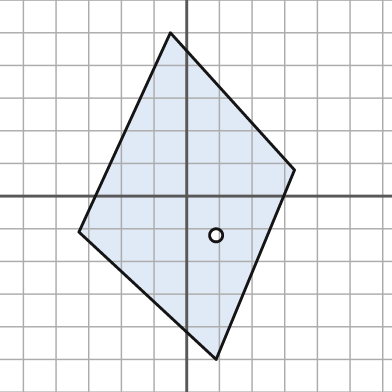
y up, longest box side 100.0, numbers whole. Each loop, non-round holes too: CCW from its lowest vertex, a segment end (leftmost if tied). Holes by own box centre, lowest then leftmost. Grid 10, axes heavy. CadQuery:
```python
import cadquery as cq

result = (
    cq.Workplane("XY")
    .moveTo(9.0, -50.0)
    .lineTo(33.0, 8.0)
    .lineTo(-5.0, 50.0)
    .lineTo(-33.0, -11.0)
    .close()
    .moveTo(9.0, -12.0)
    .circle(2.0)
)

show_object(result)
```